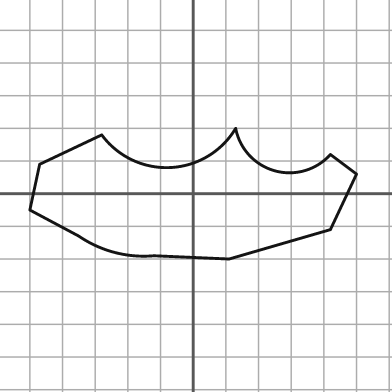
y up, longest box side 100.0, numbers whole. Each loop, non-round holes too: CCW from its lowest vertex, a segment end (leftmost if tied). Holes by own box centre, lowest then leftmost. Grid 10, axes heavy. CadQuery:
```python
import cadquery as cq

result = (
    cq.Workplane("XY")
    .moveTo(11.0, -20.0)
    .lineTo(42.0, -11.0)
    .lineTo(50.0, 6.0)
    .lineTo(42.0, 12.0)
    .threePointArc((25.0, 7.0), (13.0, 20.0))
    .threePointArc((-7.0, 8.0), (-28.0, 18.0))
    .lineTo(-47.0, 9.0)
    .lineTo(-50.0, -5.0)
    .lineTo(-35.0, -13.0)
    .threePointArc((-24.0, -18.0), (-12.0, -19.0))
    .close()
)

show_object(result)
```